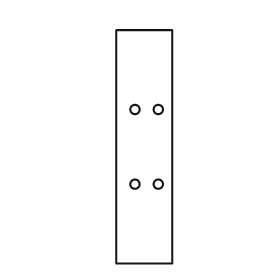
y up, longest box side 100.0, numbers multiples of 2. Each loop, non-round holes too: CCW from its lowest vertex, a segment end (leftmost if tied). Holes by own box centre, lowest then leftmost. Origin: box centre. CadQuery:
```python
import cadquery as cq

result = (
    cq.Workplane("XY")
    .moveTo(-12.0, -50.0)
    .lineTo(12.0, -50.0)
    .lineTo(12.0, 50.0)
    .lineTo(-12.0, 50.0)
    .close()
    .moveTo(-4.0, -16.0)
    .circle(2.0)
    .moveTo(6.0, -16.0)
    .circle(2.0)
    .moveTo(-4.0, 16.0)
    .circle(2.0)
    .moveTo(6.0, 16.0)
    .circle(2.0)
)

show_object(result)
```